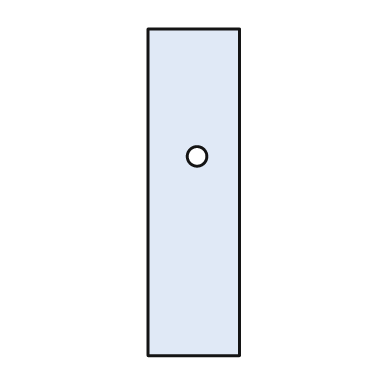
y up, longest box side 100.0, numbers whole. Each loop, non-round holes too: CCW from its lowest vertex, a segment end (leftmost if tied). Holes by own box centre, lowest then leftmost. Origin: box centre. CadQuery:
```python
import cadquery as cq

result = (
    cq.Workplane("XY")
    .moveTo(-14.0, -50.0)
    .lineTo(14.0, -50.0)
    .lineTo(14.0, 50.0)
    .lineTo(-14.0, 50.0)
    .close()
    .moveTo(1.0, 11.0)
    .circle(3.0)
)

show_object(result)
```